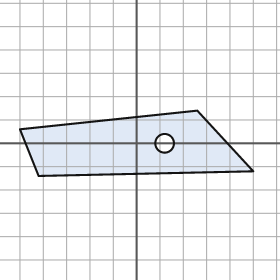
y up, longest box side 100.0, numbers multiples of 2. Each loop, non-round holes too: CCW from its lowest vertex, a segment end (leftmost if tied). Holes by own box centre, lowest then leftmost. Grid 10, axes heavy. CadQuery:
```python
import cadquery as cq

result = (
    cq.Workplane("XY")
    .moveTo(-42.0, -14.0)
    .lineTo(50.0, -12.0)
    .lineTo(26.0, 14.0)
    .lineTo(-50.0, 6.0)
    .close()
    .moveTo(12.0, 0.0)
    .circle(4.0)
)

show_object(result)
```